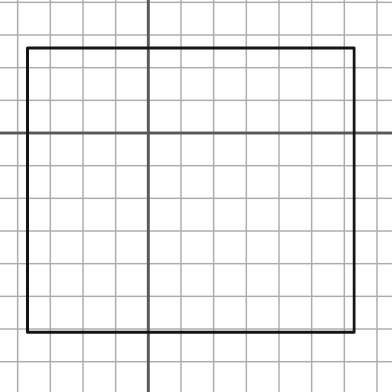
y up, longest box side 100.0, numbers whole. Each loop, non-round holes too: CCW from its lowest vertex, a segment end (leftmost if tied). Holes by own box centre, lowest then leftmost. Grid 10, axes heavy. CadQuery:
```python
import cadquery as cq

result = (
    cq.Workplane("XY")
    .moveTo(-37.0, -61.0)
    .lineTo(63.0, -61.0)
    .lineTo(63.0, 26.0)
    .lineTo(-37.0, 26.0)
    .close()
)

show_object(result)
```